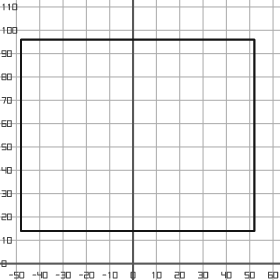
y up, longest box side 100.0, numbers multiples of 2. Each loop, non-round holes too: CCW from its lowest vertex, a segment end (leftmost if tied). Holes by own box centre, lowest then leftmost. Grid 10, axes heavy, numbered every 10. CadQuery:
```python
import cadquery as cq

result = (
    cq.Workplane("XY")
    .moveTo(-48.0, 14.0)
    .lineTo(52.0, 14.0)
    .lineTo(52.0, 96.0)
    .lineTo(-48.0, 96.0)
    .close()
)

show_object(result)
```